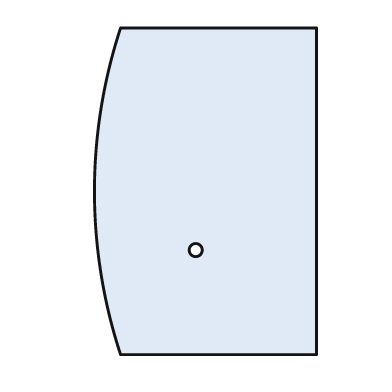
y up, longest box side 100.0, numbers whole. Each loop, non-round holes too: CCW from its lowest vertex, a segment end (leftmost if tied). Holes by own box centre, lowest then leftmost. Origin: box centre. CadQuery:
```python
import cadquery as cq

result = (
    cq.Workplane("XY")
    .moveTo(-26.0, -50.0)
    .lineTo(34.0, -50.0)
    .lineTo(34.0, 50.0)
    .lineTo(-26.0, 50.0)
    .threePointArc((-34.0, 0.0), (-26.0, -50.0))
    .close()
    .moveTo(-3.0, -18.0)
    .circle(2.0)
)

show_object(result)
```